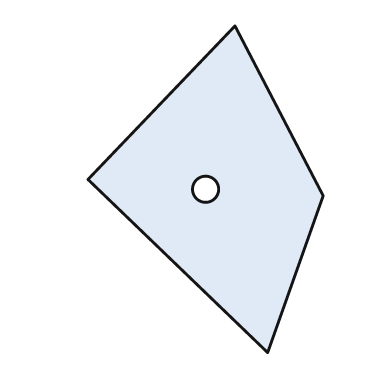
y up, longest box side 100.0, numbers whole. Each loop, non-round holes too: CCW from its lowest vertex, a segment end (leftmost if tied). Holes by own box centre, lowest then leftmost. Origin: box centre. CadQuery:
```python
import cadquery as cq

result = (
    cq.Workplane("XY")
    .moveTo(19.0, -50.0)
    .lineTo(36.0, -2.0)
    .lineTo(9.0, 50.0)
    .lineTo(-36.0, 3.0)
    .close()
    .moveTo(0.0, 0.0)
    .circle(4.0)
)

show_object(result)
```